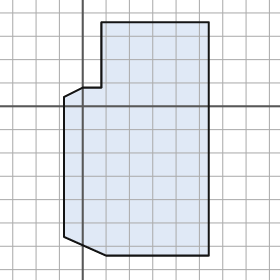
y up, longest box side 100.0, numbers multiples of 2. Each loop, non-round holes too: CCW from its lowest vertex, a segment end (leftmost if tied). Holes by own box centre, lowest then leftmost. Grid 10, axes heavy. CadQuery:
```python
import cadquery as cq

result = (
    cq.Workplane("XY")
    .moveTo(10.0, -64.0)
    .lineTo(54.0, -64.0)
    .lineTo(54.0, 36.0)
    .lineTo(8.0, 36.0)
    .lineTo(8.0, 8.0)
    .lineTo(0.0, 8.0)
    .lineTo(-8.0, 4.0)
    .lineTo(-8.0, -56.0)
    .close()
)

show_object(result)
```